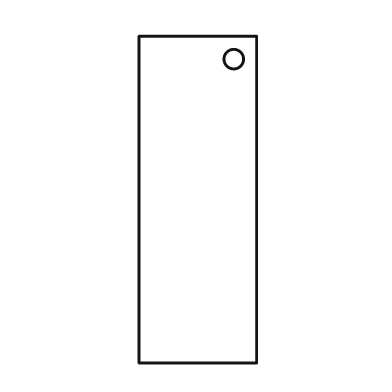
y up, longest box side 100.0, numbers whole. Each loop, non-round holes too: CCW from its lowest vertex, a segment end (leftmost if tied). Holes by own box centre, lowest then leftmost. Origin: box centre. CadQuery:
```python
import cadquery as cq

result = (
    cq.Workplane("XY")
    .moveTo(-18.0, -50.0)
    .lineTo(18.0, -50.0)
    .lineTo(18.0, 50.0)
    .lineTo(-18.0, 50.0)
    .close()
    .moveTo(11.0, 43.0)
    .circle(3.0)
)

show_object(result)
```